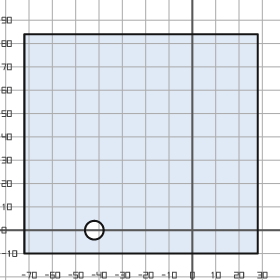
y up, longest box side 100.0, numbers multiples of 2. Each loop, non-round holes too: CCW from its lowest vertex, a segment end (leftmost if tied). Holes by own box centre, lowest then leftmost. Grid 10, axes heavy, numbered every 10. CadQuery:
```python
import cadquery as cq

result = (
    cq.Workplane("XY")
    .moveTo(-72.0, -10.0)
    .lineTo(28.0, -10.0)
    .lineTo(28.0, 84.0)
    .lineTo(-72.0, 84.0)
    .close()
    .moveTo(-42.0, 0.0)
    .circle(4.0)
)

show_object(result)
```